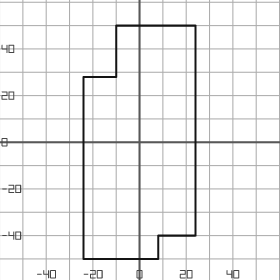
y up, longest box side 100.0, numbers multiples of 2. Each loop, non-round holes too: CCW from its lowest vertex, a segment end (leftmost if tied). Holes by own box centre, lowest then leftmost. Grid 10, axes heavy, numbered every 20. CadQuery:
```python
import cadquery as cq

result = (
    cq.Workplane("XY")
    .moveTo(-24.0, -50.0)
    .lineTo(8.0, -50.0)
    .lineTo(8.0, -40.0)
    .lineTo(24.0, -40.0)
    .lineTo(24.0, 50.0)
    .lineTo(-10.0, 50.0)
    .lineTo(-10.0, 28.0)
    .lineTo(-24.0, 28.0)
    .close()
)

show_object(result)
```